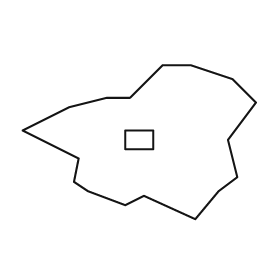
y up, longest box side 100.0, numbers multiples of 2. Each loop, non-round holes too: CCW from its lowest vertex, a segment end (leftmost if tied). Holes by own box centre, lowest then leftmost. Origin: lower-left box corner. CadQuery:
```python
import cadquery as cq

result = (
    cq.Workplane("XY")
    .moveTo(74.0, 0.0)
    .lineTo(84.0, 12.0)
    .lineTo(92.0, 18.0)
    .lineTo(88.0, 34.0)
    .lineTo(100.0, 50.0)
    .lineTo(90.0, 60.0)
    .lineTo(72.0, 66.0)
    .lineTo(60.0, 66.0)
    .lineTo(46.0, 52.0)
    .lineTo(36.0, 52.0)
    .lineTo(20.0, 48.0)
    .lineTo(0.0, 38.0)
    .lineTo(24.0, 26.0)
    .lineTo(22.0, 16.0)
    .lineTo(28.0, 12.0)
    .lineTo(44.0, 6.0)
    .lineTo(52.0, 10.0)
    .close()
    .moveTo(44.0, 30.0)
    .lineTo(56.0, 30.0)
    .lineTo(56.0, 38.0)
    .lineTo(44.0, 38.0)
    .close()
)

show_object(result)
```